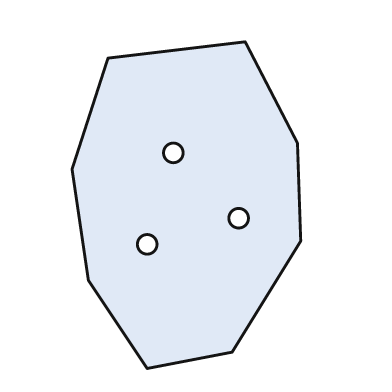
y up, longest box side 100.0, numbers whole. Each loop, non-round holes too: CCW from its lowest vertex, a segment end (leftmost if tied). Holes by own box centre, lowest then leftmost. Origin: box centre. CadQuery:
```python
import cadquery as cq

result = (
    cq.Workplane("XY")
    .moveTo(-12.0, -50.0)
    .lineTo(14.0, -45.0)
    .lineTo(35.0, -11.0)
    .lineTo(34.0, 19.0)
    .lineTo(18.0, 50.0)
    .lineTo(-24.0, 45.0)
    .lineTo(-35.0, 11.0)
    .lineTo(-30.0, -23.0)
    .close()
    .moveTo(-12.0, -12.0)
    .circle(3.0)
    .moveTo(16.0, -4.0)
    .circle(3.0)
    .moveTo(-4.0, 16.0)
    .circle(3.0)
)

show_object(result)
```